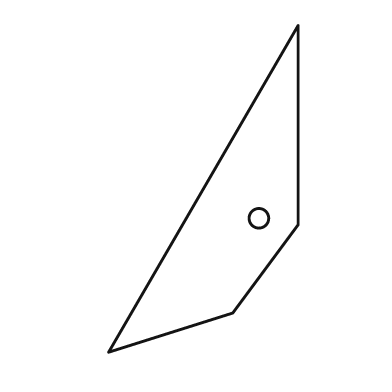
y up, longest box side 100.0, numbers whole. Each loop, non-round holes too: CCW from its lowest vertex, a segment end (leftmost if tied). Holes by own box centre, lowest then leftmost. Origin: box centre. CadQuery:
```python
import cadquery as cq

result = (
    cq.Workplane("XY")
    .moveTo(-29.0, -50.0)
    .lineTo(9.0, -38.0)
    .lineTo(29.0, -11.0)
    .lineTo(29.0, 50.0)
    .close()
    .moveTo(17.0, -9.0)
    .circle(3.0)
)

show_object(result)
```